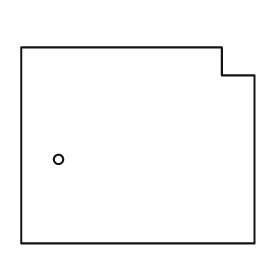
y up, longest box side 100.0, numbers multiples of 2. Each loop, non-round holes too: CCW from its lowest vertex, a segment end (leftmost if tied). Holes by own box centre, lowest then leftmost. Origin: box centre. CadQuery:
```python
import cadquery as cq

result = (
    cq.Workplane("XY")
    .moveTo(-50.0, -42.0)
    .lineTo(50.0, -42.0)
    .lineTo(50.0, 30.0)
    .lineTo(36.0, 30.0)
    .lineTo(36.0, 42.0)
    .lineTo(-50.0, 42.0)
    .close()
    .moveTo(-34.0, -6.0)
    .circle(2.0)
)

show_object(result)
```